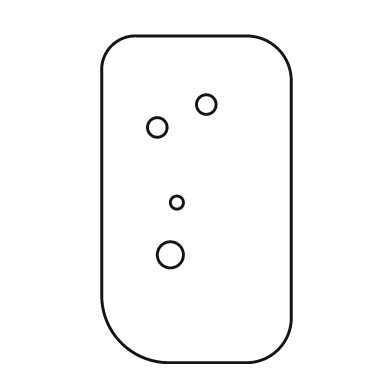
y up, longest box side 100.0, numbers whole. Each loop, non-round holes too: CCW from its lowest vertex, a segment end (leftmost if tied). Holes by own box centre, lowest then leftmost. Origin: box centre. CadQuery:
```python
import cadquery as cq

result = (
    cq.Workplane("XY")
    .moveTo(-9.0, -50.0)
    .lineTo(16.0, -50.0)
    .threePointArc((25.0, -46.0), (29.0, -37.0))
    .lineTo(29.0, 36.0)
    .threePointArc((25.0, 46.0), (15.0, 50.0))
    .lineTo(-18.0, 50.0)
    .threePointArc((-26.0, 47.0), (-29.0, 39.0))
    .lineTo(-29.0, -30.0)
    .threePointArc((-23.0, -44.0), (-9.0, -50.0))
    .close()
    .moveTo(-8.0, -17.0)
    .circle(4.0)
    .moveTo(-6.0, -1.0)
    .circle(2.0)
    .moveTo(-12.0, 22.0)
    .circle(3.0)
    .moveTo(3.0, 29.0)
    .circle(3.0)
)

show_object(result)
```